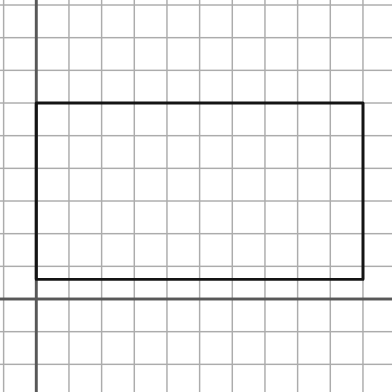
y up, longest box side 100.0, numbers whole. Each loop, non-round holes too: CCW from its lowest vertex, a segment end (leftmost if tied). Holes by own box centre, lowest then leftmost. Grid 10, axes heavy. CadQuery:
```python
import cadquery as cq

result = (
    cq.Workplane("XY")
    .moveTo(0.0, 6.0)
    .lineTo(100.0, 6.0)
    .lineTo(100.0, 60.0)
    .lineTo(0.0, 60.0)
    .close()
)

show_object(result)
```